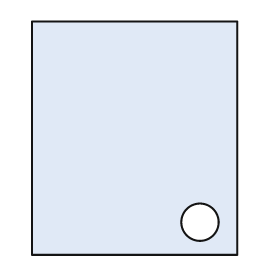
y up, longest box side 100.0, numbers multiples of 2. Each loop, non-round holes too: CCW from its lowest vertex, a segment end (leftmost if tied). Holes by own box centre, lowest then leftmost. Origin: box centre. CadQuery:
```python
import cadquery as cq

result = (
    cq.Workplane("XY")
    .moveTo(-44.0, -50.0)
    .lineTo(44.0, -50.0)
    .lineTo(44.0, 50.0)
    .lineTo(-44.0, 50.0)
    .close()
    .moveTo(28.0, -36.0)
    .circle(8.0)
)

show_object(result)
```